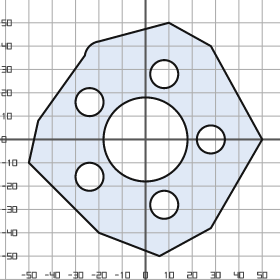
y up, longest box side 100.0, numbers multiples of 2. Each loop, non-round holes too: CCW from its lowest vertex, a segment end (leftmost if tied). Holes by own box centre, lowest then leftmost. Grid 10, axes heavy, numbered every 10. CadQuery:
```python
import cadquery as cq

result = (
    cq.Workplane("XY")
    .moveTo(6.0, -50.0)
    .lineTo(28.0, -38.0)
    .lineTo(50.0, 0.0)
    .lineTo(28.0, 40.0)
    .lineTo(10.0, 50.0)
    .lineTo(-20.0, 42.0)
    .threePointArc((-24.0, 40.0), (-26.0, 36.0))
    .lineTo(-46.0, 8.0)
    .lineTo(-50.0, -10.0)
    .lineTo(-20.0, -40.0)
    .close()
    .moveTo(8.0, -28.0)
    .circle(6.0)
    .moveTo(-24.0, -16.0)
    .circle(6.0)
    .moveTo(0.0, 0.0)
    .circle(18.0)
    .moveTo(28.0, 0.0)
    .circle(6.0)
    .moveTo(-24.0, 16.0)
    .circle(6.0)
    .moveTo(8.0, 28.0)
    .circle(6.0)
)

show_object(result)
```